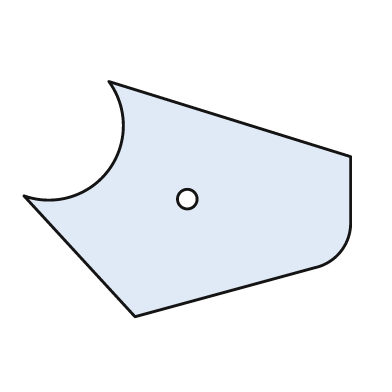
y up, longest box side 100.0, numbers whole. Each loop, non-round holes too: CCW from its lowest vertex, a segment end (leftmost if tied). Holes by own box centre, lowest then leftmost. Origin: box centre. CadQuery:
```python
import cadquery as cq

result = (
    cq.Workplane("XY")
    .moveTo(-16.0, -36.0)
    .lineTo(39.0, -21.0)
    .threePointArc((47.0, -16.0), (50.0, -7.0))
    .lineTo(50.0, 13.0)
    .lineTo(-24.0, 36.0)
    .threePointArc((-24.0, 9.0), (-50.0, 1.0))
    .close()
    .moveTo(0.0, 0.0)
    .circle(3.0)
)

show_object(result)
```